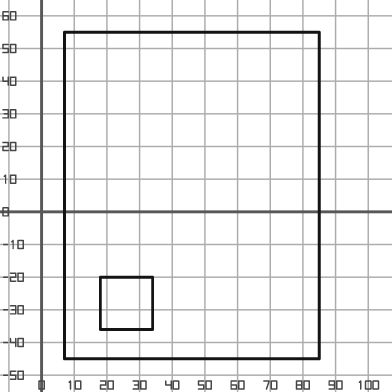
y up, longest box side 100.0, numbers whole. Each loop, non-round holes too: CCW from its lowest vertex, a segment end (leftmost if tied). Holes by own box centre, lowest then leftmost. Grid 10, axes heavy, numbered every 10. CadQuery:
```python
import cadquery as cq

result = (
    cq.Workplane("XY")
    .moveTo(7.0, -45.0)
    .lineTo(85.0, -45.0)
    .lineTo(85.0, 55.0)
    .lineTo(7.0, 55.0)
    .close()
    .moveTo(18.0, -36.0)
    .lineTo(34.0, -36.0)
    .lineTo(34.0, -20.0)
    .lineTo(18.0, -20.0)
    .close()
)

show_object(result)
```